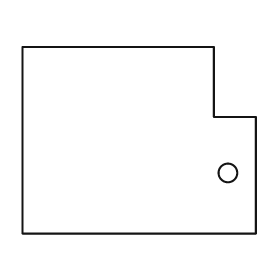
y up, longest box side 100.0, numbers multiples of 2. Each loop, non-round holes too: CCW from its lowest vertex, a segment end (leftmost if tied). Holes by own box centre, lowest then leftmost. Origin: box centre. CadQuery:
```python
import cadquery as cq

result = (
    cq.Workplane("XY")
    .moveTo(-50.0, -40.0)
    .lineTo(50.0, -40.0)
    .lineTo(50.0, 10.0)
    .lineTo(32.0, 10.0)
    .lineTo(32.0, 40.0)
    .lineTo(-50.0, 40.0)
    .close()
    .moveTo(38.0, -14.0)
    .circle(4.0)
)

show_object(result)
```